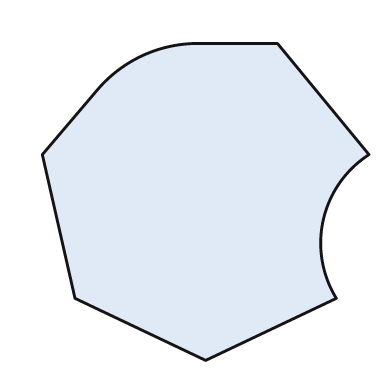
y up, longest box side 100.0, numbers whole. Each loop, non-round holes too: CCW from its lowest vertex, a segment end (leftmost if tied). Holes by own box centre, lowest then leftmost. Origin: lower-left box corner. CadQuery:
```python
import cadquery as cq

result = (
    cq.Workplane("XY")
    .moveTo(50.0, 0.0)
    .lineTo(90.0, 19.0)
    .threePointArc((86.0, 43.0), (100.0, 63.0))
    .lineTo(72.0, 97.0)
    .lineTo(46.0, 97.0)
    .threePointArc((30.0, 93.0), (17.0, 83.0))
    .lineTo(0.0, 63.0)
    .lineTo(10.0, 19.0)
    .close()
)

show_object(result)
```